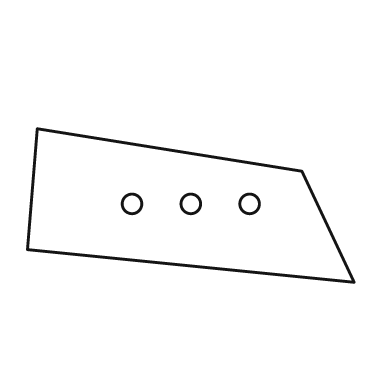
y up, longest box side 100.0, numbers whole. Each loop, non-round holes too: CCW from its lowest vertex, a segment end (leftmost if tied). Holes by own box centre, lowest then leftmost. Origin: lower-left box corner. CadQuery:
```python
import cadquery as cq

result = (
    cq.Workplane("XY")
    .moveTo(100.0, 0.0)
    .lineTo(84.0, 34.0)
    .lineTo(3.0, 47.0)
    .lineTo(0.0, 10.0)
    .close()
    .moveTo(32.0, 24.0)
    .circle(3.0)
    .moveTo(50.0, 24.0)
    .circle(3.0)
    .moveTo(68.0, 24.0)
    .circle(3.0)
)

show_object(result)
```